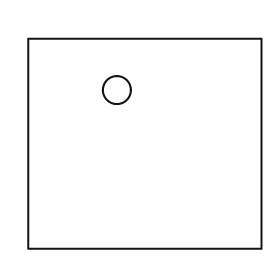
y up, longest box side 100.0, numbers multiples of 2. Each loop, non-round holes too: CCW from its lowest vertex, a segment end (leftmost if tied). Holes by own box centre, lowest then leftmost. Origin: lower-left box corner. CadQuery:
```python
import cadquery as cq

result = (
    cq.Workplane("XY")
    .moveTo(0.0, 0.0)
    .lineTo(100.0, 0.0)
    .lineTo(100.0, 90.0)
    .lineTo(0.0, 90.0)
    .close()
    .moveTo(38.0, 68.0)
    .circle(6.0)
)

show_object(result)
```